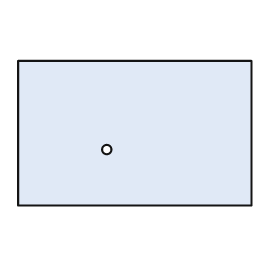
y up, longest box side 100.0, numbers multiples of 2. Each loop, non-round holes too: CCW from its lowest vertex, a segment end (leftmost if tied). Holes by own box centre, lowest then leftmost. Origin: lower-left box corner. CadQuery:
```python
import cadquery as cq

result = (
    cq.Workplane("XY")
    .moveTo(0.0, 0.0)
    .lineTo(100.0, 0.0)
    .lineTo(100.0, 62.0)
    .lineTo(0.0, 62.0)
    .close()
    .moveTo(38.0, 24.0)
    .circle(2.0)
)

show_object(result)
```